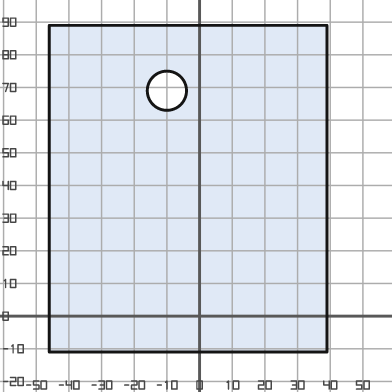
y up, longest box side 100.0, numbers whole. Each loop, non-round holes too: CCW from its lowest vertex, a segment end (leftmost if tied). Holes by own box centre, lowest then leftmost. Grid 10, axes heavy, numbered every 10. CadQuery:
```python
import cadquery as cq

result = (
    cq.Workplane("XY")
    .moveTo(-46.0, -11.0)
    .lineTo(39.0, -11.0)
    .lineTo(39.0, 89.0)
    .lineTo(-46.0, 89.0)
    .close()
    .moveTo(-10.0, 69.0)
    .circle(6.0)
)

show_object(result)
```